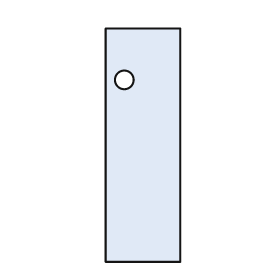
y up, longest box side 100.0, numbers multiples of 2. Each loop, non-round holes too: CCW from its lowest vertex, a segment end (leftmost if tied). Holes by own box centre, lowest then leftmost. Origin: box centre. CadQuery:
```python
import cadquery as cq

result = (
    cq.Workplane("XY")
    .moveTo(-16.0, -50.0)
    .lineTo(16.0, -50.0)
    .lineTo(16.0, 50.0)
    .lineTo(-16.0, 50.0)
    .close()
    .moveTo(-8.0, 28.0)
    .circle(4.0)
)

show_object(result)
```